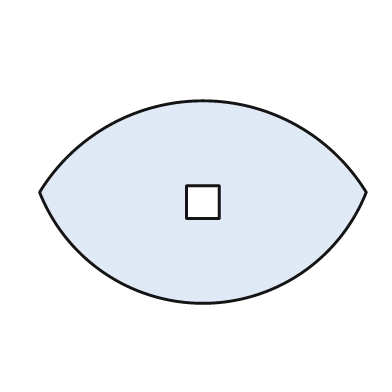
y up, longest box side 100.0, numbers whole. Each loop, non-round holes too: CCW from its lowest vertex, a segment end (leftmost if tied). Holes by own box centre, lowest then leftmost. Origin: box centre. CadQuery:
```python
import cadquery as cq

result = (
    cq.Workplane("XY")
    .moveTo(-50.0, 3.0)
    .threePointArc((0.0, -31.0), (50.0, 3.0))
    .threePointArc((0.0, 31.0), (-50.0, 3.0))
    .close()
    .moveTo(-5.0, -5.0)
    .lineTo(5.0, -5.0)
    .lineTo(5.0, 5.0)
    .lineTo(-5.0, 5.0)
    .close()
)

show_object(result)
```